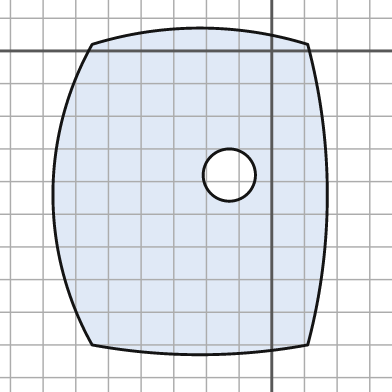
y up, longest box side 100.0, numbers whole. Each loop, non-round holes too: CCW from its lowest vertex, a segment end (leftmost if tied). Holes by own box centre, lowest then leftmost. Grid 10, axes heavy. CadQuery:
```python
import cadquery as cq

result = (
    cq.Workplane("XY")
    .moveTo(-55.0, -90.0)
    .threePointArc((-22.0, -93.0), (11.0, -90.0))
    .threePointArc((17.0, -44.0), (11.0, 2.0))
    .threePointArc((-22.0, 7.0), (-55.0, 2.0))
    .threePointArc((-67.0, -44.0), (-55.0, -90.0))
    .close()
    .moveTo(-13.0, -38.0)
    .circle(8.0)
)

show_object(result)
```